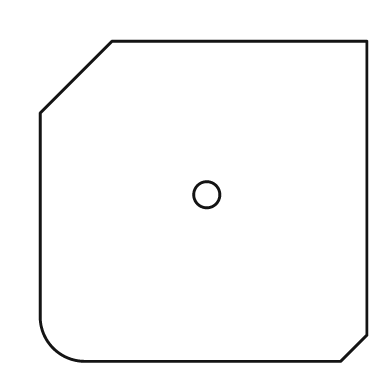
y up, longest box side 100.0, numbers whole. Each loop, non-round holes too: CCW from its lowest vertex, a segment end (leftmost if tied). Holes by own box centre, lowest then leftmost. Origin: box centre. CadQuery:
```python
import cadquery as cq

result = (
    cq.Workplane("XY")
    .moveTo(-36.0, -49.0)
    .lineTo(42.0, -49.0)
    .lineTo(50.0, -41.0)
    .lineTo(50.0, 49.0)
    .lineTo(-28.0, 49.0)
    .lineTo(-50.0, 27.0)
    .lineTo(-50.0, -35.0)
    .threePointArc((-46.0, -45.0), (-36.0, -49.0))
    .close()
    .moveTo(1.0, 2.0)
    .circle(4.0)
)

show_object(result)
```